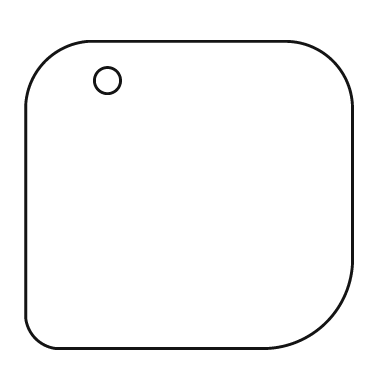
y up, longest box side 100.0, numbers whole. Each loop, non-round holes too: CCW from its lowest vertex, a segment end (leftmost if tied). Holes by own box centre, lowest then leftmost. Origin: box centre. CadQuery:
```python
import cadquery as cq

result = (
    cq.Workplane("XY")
    .moveTo(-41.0, -47.0)
    .lineTo(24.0, -47.0)
    .threePointArc((42.0, -39.0), (50.0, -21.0))
    .lineTo(50.0, 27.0)
    .threePointArc((44.0, 41.0), (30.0, 47.0))
    .lineTo(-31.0, 47.0)
    .threePointArc((-44.0, 41.0), (-50.0, 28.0))
    .lineTo(-50.0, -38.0)
    .threePointArc((-47.0, -44.0), (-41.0, -47.0))
    .close()
    .moveTo(-25.0, 35.0)
    .circle(4.0)
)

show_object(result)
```